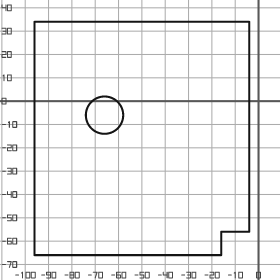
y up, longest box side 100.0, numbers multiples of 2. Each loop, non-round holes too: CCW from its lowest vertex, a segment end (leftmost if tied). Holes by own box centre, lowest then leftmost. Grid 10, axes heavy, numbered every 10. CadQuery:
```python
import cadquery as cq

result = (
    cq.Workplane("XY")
    .moveTo(-96.0, -66.0)
    .lineTo(-16.0, -66.0)
    .lineTo(-16.0, -56.0)
    .lineTo(-4.0, -56.0)
    .lineTo(-4.0, 34.0)
    .lineTo(-96.0, 34.0)
    .close()
    .moveTo(-66.0, -6.0)
    .circle(8.0)
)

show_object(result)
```